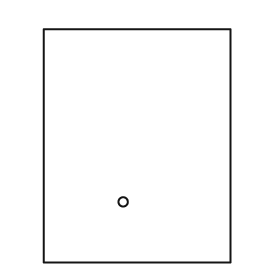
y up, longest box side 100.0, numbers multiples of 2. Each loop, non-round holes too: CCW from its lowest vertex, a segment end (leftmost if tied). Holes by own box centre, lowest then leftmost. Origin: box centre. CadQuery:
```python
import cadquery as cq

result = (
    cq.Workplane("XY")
    .moveTo(-40.0, -50.0)
    .lineTo(40.0, -50.0)
    .lineTo(40.0, 50.0)
    .lineTo(-40.0, 50.0)
    .close()
    .moveTo(-6.0, -24.0)
    .circle(2.0)
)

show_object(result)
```